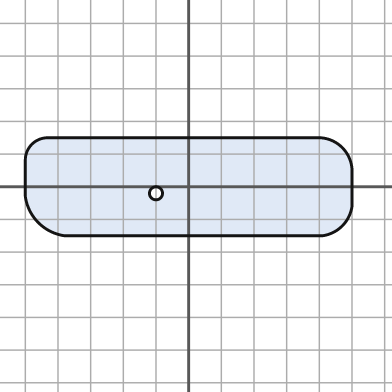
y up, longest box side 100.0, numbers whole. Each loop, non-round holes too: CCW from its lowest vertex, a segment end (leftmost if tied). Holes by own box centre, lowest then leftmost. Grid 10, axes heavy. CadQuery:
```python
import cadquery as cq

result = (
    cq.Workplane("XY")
    .moveTo(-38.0, -15.0)
    .lineTo(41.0, -15.0)
    .threePointArc((47.0, -12.0), (50.0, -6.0))
    .lineTo(50.0, 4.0)
    .threePointArc((47.0, 12.0), (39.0, 15.0))
    .lineTo(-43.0, 15.0)
    .threePointArc((-48.0, 13.0), (-50.0, 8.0))
    .lineTo(-50.0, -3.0)
    .threePointArc((-46.0, -11.0), (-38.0, -15.0))
    .close()
    .moveTo(-10.0, -2.0)
    .circle(2.0)
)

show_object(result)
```